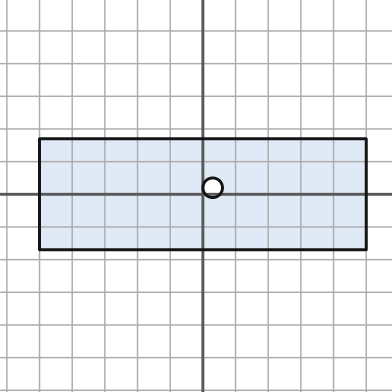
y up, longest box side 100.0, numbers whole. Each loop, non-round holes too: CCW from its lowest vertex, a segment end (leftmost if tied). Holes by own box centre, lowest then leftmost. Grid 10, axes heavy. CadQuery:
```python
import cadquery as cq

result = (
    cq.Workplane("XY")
    .moveTo(-50.0, -17.0)
    .lineTo(50.0, -17.0)
    .lineTo(50.0, 17.0)
    .lineTo(-50.0, 17.0)
    .close()
    .moveTo(3.0, 2.0)
    .circle(3.0)
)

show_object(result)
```